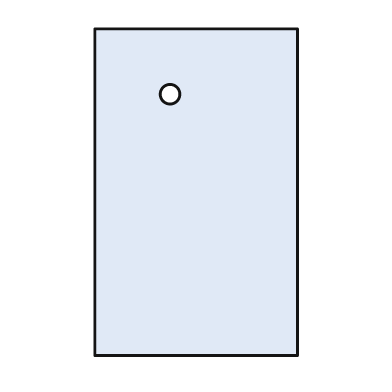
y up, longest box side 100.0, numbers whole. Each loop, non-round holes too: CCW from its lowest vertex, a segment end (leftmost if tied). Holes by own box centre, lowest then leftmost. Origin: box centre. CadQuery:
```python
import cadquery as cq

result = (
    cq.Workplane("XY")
    .moveTo(-31.0, -50.0)
    .lineTo(31.0, -50.0)
    .lineTo(31.0, 50.0)
    .lineTo(-31.0, 50.0)
    .close()
    .moveTo(-8.0, 30.0)
    .circle(3.0)
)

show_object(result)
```